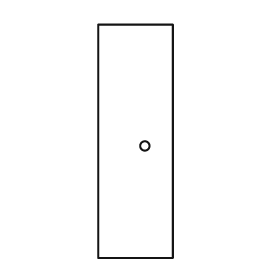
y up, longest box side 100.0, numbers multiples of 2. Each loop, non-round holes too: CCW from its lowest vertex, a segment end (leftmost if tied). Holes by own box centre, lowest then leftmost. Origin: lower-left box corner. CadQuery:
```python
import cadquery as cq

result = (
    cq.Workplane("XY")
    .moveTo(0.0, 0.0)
    .lineTo(32.0, 0.0)
    .lineTo(32.0, 100.0)
    .lineTo(0.0, 100.0)
    .close()
    .moveTo(20.0, 48.0)
    .circle(2.0)
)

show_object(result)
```